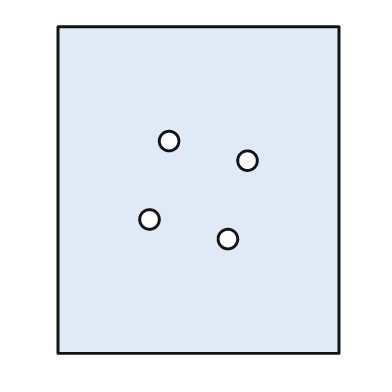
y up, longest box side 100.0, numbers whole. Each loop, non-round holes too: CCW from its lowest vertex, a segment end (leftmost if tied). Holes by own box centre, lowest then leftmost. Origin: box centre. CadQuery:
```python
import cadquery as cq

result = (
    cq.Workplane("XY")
    .moveTo(-43.0, -50.0)
    .lineTo(43.0, -50.0)
    .lineTo(43.0, 50.0)
    .lineTo(-43.0, 50.0)
    .close()
    .moveTo(9.0, -15.0)
    .circle(3.0)
    .moveTo(-15.0, -9.0)
    .circle(3.0)
    .moveTo(15.0, 9.0)
    .circle(3.0)
    .moveTo(-9.0, 15.0)
    .circle(3.0)
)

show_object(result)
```